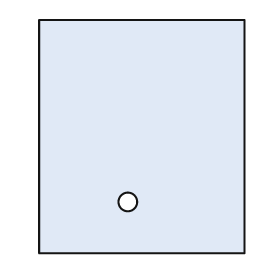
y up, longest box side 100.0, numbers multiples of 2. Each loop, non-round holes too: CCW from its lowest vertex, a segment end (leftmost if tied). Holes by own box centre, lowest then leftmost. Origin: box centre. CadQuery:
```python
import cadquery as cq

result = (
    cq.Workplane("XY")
    .moveTo(-44.0, -50.0)
    .lineTo(44.0, -50.0)
    .lineTo(44.0, 50.0)
    .lineTo(-44.0, 50.0)
    .close()
    .moveTo(-6.0, -28.0)
    .circle(4.0)
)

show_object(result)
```